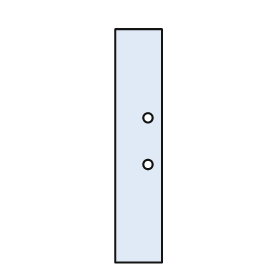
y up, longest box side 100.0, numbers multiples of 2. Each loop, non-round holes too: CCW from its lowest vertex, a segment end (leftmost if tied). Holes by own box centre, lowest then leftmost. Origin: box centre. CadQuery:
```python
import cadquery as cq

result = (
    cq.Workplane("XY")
    .moveTo(-10.0, -50.0)
    .lineTo(10.0, -50.0)
    .lineTo(10.0, 50.0)
    .lineTo(-10.0, 50.0)
    .close()
    .moveTo(4.0, -8.0)
    .circle(2.0)
    .moveTo(4.0, 12.0)
    .circle(2.0)
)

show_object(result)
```